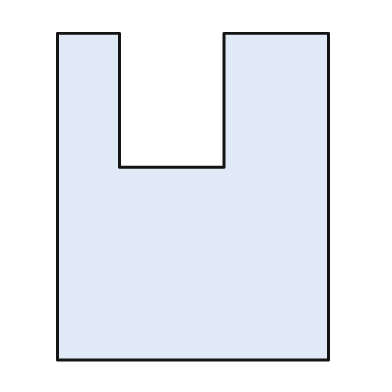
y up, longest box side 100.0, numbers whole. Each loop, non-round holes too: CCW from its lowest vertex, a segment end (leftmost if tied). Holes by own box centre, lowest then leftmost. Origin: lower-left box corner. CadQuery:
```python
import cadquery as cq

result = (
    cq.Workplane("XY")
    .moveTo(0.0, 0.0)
    .lineTo(83.0, 0.0)
    .lineTo(83.0, 100.0)
    .lineTo(51.0, 100.0)
    .lineTo(51.0, 59.0)
    .lineTo(19.0, 59.0)
    .lineTo(19.0, 100.0)
    .lineTo(0.0, 100.0)
    .close()
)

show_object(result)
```